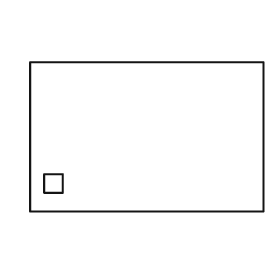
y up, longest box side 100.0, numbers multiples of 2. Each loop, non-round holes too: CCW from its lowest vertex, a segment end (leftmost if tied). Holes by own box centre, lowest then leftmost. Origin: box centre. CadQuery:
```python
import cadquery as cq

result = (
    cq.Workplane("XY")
    .moveTo(-50.0, -32.0)
    .lineTo(50.0, -32.0)
    .lineTo(50.0, 32.0)
    .lineTo(-50.0, 32.0)
    .close()
    .moveTo(-44.0, -24.0)
    .lineTo(-36.0, -24.0)
    .lineTo(-36.0, -16.0)
    .lineTo(-44.0, -16.0)
    .close()
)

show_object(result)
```